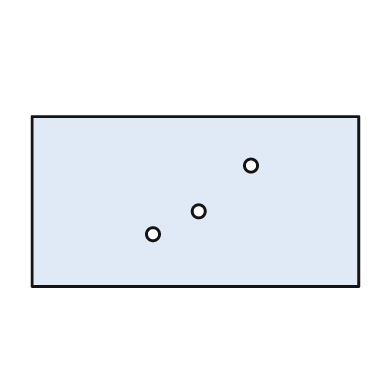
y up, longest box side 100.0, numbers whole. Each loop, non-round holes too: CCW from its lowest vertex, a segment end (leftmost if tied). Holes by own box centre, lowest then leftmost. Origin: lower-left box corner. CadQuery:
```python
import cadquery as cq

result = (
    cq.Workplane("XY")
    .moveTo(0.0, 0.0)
    .lineTo(100.0, 0.0)
    .lineTo(100.0, 52.0)
    .lineTo(0.0, 52.0)
    .close()
    .moveTo(37.0, 16.0)
    .circle(2.0)
    .moveTo(51.0, 23.0)
    .circle(2.0)
    .moveTo(67.0, 37.0)
    .circle(2.0)
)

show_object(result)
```